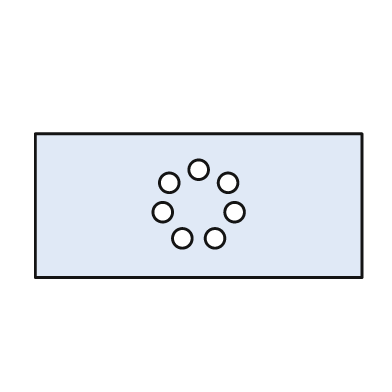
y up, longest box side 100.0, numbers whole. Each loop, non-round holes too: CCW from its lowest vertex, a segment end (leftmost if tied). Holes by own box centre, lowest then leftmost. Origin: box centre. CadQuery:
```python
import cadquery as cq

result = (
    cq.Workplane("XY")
    .moveTo(-50.0, -22.0)
    .lineTo(50.0, -22.0)
    .lineTo(50.0, 22.0)
    .lineTo(-50.0, 22.0)
    .close()
    .moveTo(-5.0, -10.0)
    .circle(3.0)
    .moveTo(5.0, -10.0)
    .circle(3.0)
    .moveTo(-11.0, -2.0)
    .circle(3.0)
    .moveTo(11.0, -2.0)
    .circle(3.0)
    .moveTo(-9.0, 7.0)
    .circle(3.0)
    .moveTo(9.0, 7.0)
    .circle(3.0)
    .moveTo(0.0, 11.0)
    .circle(3.0)
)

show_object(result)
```